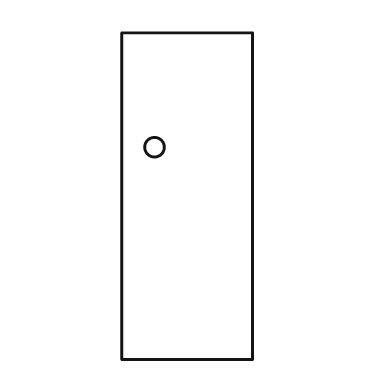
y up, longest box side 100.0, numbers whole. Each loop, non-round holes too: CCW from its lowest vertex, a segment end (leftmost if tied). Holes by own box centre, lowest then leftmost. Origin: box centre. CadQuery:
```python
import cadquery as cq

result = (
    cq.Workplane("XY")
    .moveTo(-20.0, -50.0)
    .lineTo(20.0, -50.0)
    .lineTo(20.0, 50.0)
    .lineTo(-20.0, 50.0)
    .close()
    .moveTo(-10.0, 15.0)
    .circle(3.0)
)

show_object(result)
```